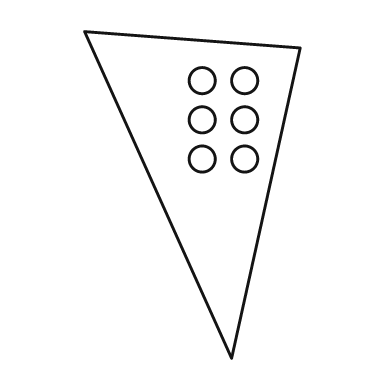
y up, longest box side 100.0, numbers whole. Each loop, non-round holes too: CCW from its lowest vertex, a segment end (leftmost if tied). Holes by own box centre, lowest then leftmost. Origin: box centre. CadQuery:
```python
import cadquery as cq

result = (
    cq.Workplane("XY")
    .moveTo(12.0, -50.0)
    .lineTo(33.0, 45.0)
    .lineTo(-33.0, 50.0)
    .close()
    .moveTo(3.0, 11.0)
    .circle(4.0)
    .moveTo(16.0, 11.0)
    .circle(4.0)
    .moveTo(3.0, 23.0)
    .circle(4.0)
    .moveTo(16.0, 23.0)
    .circle(4.0)
    .moveTo(3.0, 35.0)
    .circle(4.0)
    .moveTo(16.0, 35.0)
    .circle(4.0)
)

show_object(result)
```